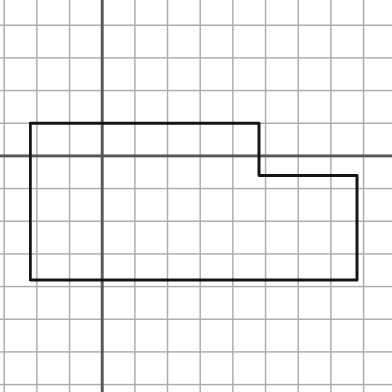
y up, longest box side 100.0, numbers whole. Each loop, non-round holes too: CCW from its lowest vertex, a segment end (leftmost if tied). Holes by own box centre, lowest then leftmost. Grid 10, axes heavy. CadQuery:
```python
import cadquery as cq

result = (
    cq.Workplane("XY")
    .moveTo(-22.0, -38.0)
    .lineTo(78.0, -38.0)
    .lineTo(78.0, -6.0)
    .lineTo(48.0, -6.0)
    .lineTo(48.0, 10.0)
    .lineTo(-22.0, 10.0)
    .close()
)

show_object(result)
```